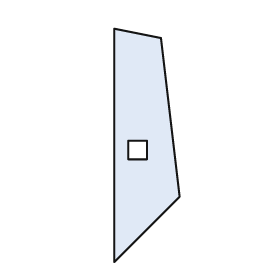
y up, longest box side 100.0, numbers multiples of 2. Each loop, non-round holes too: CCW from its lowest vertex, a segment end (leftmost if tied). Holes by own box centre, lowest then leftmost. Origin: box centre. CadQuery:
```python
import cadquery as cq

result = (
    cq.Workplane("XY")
    .moveTo(-14.0, -50.0)
    .lineTo(14.0, -22.0)
    .lineTo(6.0, 46.0)
    .lineTo(-14.0, 50.0)
    .close()
    .moveTo(-8.0, -6.0)
    .lineTo(0.0, -6.0)
    .lineTo(0.0, 2.0)
    .lineTo(-8.0, 2.0)
    .close()
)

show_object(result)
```